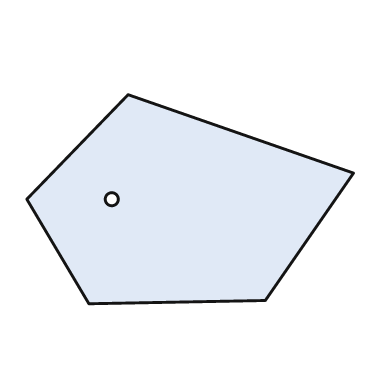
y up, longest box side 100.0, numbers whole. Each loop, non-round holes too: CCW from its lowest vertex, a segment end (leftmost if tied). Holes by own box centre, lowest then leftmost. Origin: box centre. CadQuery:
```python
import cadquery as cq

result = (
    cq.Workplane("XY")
    .moveTo(-31.0, -32.0)
    .lineTo(23.0, -31.0)
    .lineTo(50.0, 8.0)
    .lineTo(-19.0, 32.0)
    .lineTo(-50.0, 0.0)
    .close()
    .moveTo(-24.0, 0.0)
    .circle(2.0)
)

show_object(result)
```